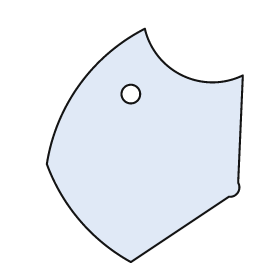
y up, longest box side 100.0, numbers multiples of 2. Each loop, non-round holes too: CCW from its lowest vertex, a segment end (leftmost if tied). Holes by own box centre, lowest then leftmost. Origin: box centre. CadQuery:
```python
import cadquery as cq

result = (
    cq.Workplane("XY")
    .moveTo(-6.0, -50.0)
    .lineTo(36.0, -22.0)
    .threePointArc((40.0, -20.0), (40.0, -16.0))
    .lineTo(42.0, 30.0)
    .threePointArc((16.0, 30.0), (0.0, 50.0))
    .threePointArc((-28.0, 26.0), (-42.0, -8.0))
    .threePointArc((-28.0, -32.0), (-6.0, -50.0))
    .close()
    .moveTo(-6.0, 22.0)
    .circle(4.0)
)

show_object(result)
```